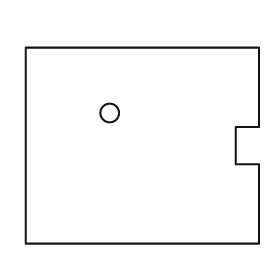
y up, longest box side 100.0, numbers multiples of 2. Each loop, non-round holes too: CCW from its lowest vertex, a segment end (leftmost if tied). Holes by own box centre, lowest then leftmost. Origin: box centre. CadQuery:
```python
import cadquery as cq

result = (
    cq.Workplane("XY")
    .moveTo(-50.0, -42.0)
    .lineTo(50.0, -42.0)
    .lineTo(50.0, -8.0)
    .lineTo(40.0, -8.0)
    .lineTo(40.0, 8.0)
    .lineTo(50.0, 8.0)
    .lineTo(50.0, 42.0)
    .lineTo(-50.0, 42.0)
    .close()
    .moveTo(-14.0, 14.0)
    .circle(4.0)
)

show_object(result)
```